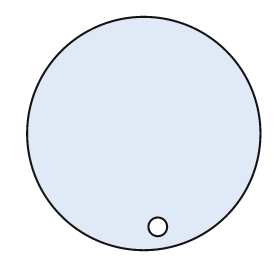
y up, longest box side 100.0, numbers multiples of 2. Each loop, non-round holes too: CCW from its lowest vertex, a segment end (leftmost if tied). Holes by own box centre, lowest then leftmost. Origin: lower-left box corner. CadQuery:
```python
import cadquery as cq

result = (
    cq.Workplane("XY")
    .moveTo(50.0, 50.0)
    .circle(50.0)
    .moveTo(56.0, 10.0)
    .circle(4.0)
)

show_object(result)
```